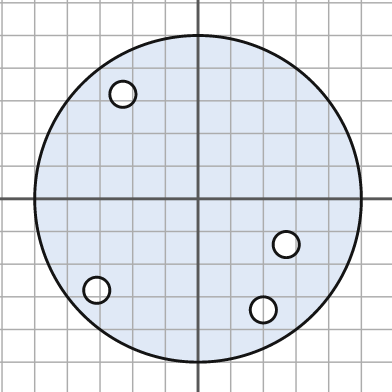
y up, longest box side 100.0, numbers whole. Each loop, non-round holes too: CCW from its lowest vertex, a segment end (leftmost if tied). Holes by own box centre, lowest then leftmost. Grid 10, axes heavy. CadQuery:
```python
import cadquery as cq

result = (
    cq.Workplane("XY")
    .moveTo(0.0, 0.0)
    .circle(50.0)
    .moveTo(20.0, -34.0)
    .circle(4.0)
    .moveTo(-31.0, -28.0)
    .circle(4.0)
    .moveTo(27.0, -14.0)
    .circle(4.0)
    .moveTo(-23.0, 32.0)
    .circle(4.0)
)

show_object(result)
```